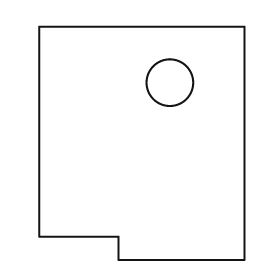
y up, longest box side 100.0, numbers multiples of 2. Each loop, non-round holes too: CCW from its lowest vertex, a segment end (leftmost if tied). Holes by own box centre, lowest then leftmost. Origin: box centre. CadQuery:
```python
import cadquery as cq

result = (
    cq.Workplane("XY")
    .moveTo(-10.0, -50.0)
    .lineTo(44.0, -50.0)
    .lineTo(44.0, 50.0)
    .lineTo(-44.0, 50.0)
    .lineTo(-44.0, -40.0)
    .lineTo(-10.0, -40.0)
    .close()
    .moveTo(12.0, 26.0)
    .circle(10.0)
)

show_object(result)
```